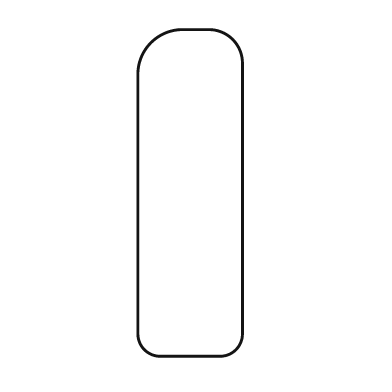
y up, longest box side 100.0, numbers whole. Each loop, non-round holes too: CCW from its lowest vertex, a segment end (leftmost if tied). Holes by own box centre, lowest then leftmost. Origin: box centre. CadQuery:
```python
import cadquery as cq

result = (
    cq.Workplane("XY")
    .moveTo(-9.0, -50.0)
    .lineTo(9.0, -50.0)
    .threePointArc((14.0, -48.0), (16.0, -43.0))
    .lineTo(16.0, 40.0)
    .threePointArc((13.0, 47.0), (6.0, 50.0))
    .lineTo(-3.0, 50.0)
    .threePointArc((-12.0, 46.0), (-16.0, 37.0))
    .lineTo(-16.0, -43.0)
    .threePointArc((-14.0, -48.0), (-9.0, -50.0))
    .close()
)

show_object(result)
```